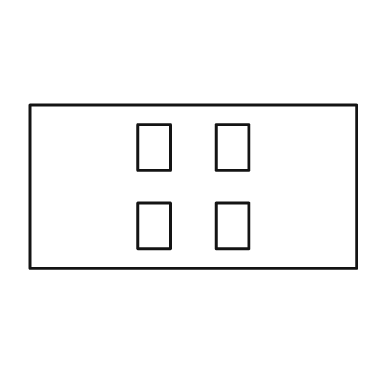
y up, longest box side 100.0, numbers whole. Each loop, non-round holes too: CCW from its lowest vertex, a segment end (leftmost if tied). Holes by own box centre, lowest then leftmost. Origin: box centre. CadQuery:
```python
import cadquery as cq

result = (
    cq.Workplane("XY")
    .moveTo(-50.0, -25.0)
    .lineTo(50.0, -25.0)
    .lineTo(50.0, 25.0)
    .lineTo(-50.0, 25.0)
    .close()
    .moveTo(-17.0, -19.0)
    .lineTo(-7.0, -19.0)
    .lineTo(-7.0, -5.0)
    .lineTo(-17.0, -5.0)
    .close()
    .moveTo(7.0, -19.0)
    .lineTo(17.0, -19.0)
    .lineTo(17.0, -5.0)
    .lineTo(7.0, -5.0)
    .close()
    .moveTo(-17.0, 5.0)
    .lineTo(-7.0, 5.0)
    .lineTo(-7.0, 19.0)
    .lineTo(-17.0, 19.0)
    .close()
    .moveTo(7.0, 5.0)
    .lineTo(17.0, 5.0)
    .lineTo(17.0, 19.0)
    .lineTo(7.0, 19.0)
    .close()
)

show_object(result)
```